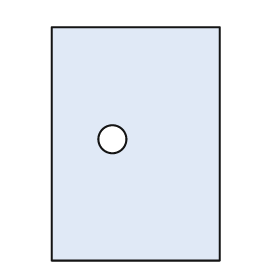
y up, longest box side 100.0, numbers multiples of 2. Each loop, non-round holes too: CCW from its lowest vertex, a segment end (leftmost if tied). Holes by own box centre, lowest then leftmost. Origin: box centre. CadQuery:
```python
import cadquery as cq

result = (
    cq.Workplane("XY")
    .moveTo(-36.0, -50.0)
    .lineTo(36.0, -50.0)
    .lineTo(36.0, 50.0)
    .lineTo(-36.0, 50.0)
    .close()
    .moveTo(-10.0, 2.0)
    .circle(6.0)
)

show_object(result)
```